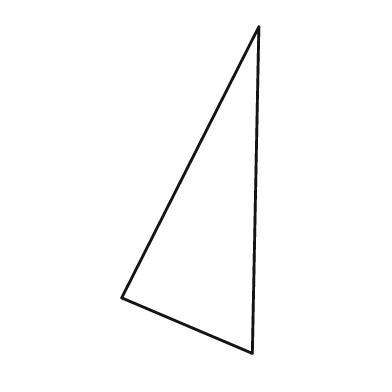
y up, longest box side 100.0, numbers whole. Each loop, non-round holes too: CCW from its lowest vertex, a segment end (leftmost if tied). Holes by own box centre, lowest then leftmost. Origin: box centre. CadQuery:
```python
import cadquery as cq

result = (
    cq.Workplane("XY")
    .moveTo(19.0, -50.0)
    .lineTo(21.0, 50.0)
    .lineTo(-21.0, -33.0)
    .close()
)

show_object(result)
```